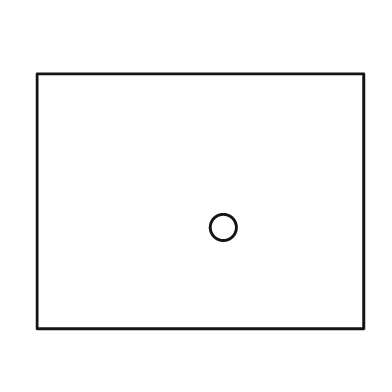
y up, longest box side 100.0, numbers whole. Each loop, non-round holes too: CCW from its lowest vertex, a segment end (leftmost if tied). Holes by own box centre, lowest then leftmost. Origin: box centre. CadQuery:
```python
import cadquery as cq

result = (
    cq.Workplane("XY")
    .moveTo(-50.0, -39.0)
    .lineTo(50.0, -39.0)
    .lineTo(50.0, 39.0)
    .lineTo(-50.0, 39.0)
    .close()
    .moveTo(7.0, -8.0)
    .circle(4.0)
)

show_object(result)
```